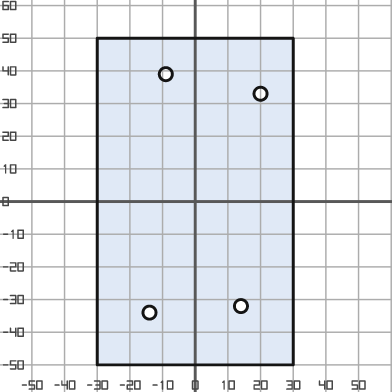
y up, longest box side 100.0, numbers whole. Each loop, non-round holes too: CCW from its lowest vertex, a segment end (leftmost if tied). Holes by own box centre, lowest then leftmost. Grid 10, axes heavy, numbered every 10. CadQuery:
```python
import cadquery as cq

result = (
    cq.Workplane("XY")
    .moveTo(-30.0, -50.0)
    .lineTo(30.0, -50.0)
    .lineTo(30.0, 50.0)
    .lineTo(-30.0, 50.0)
    .close()
    .moveTo(-14.0, -34.0)
    .circle(2.0)
    .moveTo(14.0, -32.0)
    .circle(2.0)
    .moveTo(20.0, 33.0)
    .circle(2.0)
    .moveTo(-9.0, 39.0)
    .circle(2.0)
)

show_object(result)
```